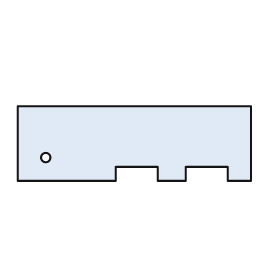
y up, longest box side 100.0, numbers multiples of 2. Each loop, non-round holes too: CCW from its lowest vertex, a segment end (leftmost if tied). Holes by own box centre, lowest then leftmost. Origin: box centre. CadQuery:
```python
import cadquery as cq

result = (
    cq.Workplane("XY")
    .moveTo(-50.0, -16.0)
    .lineTo(-8.0, -16.0)
    .lineTo(-8.0, -10.0)
    .lineTo(10.0, -10.0)
    .lineTo(10.0, -16.0)
    .lineTo(22.0, -16.0)
    .lineTo(22.0, -10.0)
    .lineTo(40.0, -10.0)
    .lineTo(40.0, -16.0)
    .lineTo(50.0, -16.0)
    .lineTo(50.0, 16.0)
    .lineTo(-50.0, 16.0)
    .close()
    .moveTo(-38.0, -6.0)
    .circle(2.0)
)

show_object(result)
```